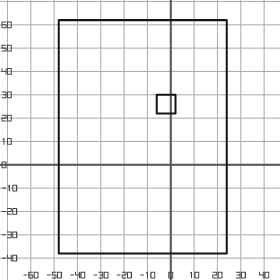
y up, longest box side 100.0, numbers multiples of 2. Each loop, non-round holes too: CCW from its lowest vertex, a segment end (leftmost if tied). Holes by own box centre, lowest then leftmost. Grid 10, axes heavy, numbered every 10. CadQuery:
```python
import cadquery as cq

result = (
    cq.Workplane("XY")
    .moveTo(-48.0, -38.0)
    .lineTo(24.0, -38.0)
    .lineTo(24.0, 62.0)
    .lineTo(-48.0, 62.0)
    .close()
    .moveTo(-6.0, 22.0)
    .lineTo(2.0, 22.0)
    .lineTo(2.0, 30.0)
    .lineTo(-6.0, 30.0)
    .close()
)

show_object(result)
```